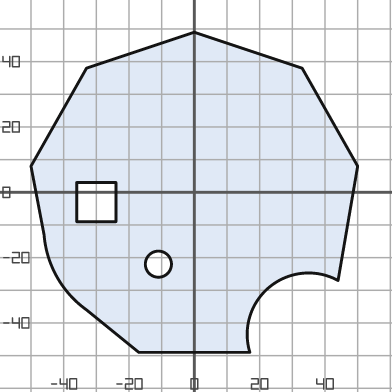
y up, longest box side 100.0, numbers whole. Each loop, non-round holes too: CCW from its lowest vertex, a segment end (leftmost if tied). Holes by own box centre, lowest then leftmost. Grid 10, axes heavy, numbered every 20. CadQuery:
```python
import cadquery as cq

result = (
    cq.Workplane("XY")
    .moveTo(-17.0, -49.0)
    .lineTo(17.0, -49.0)
    .threePointArc((23.0, -29.0), (44.0, -27.0))
    .lineTo(50.0, 8.0)
    .lineTo(33.0, 38.0)
    .lineTo(0.0, 49.0)
    .lineTo(-33.0, 38.0)
    .lineTo(-50.0, 8.0)
    .lineTo(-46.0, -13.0)
    .threePointArc((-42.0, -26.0), (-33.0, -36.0))
    .close()
    .moveTo(-11.0, -22.0)
    .circle(4.0)
    .moveTo(-36.0, -9.0)
    .lineTo(-24.0, -9.0)
    .lineTo(-24.0, 3.0)
    .lineTo(-36.0, 3.0)
    .close()
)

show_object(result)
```